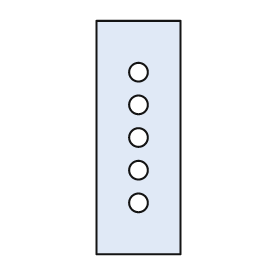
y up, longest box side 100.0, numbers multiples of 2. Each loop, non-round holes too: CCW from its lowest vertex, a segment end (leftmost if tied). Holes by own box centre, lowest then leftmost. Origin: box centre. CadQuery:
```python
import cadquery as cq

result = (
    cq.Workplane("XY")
    .moveTo(-18.0, -50.0)
    .lineTo(18.0, -50.0)
    .lineTo(18.0, 50.0)
    .lineTo(-18.0, 50.0)
    .close()
    .moveTo(0.0, -28.0)
    .circle(4.0)
    .moveTo(0.0, -14.0)
    .circle(4.0)
    .moveTo(0.0, 0.0)
    .circle(4.0)
    .moveTo(0.0, 14.0)
    .circle(4.0)
    .moveTo(0.0, 28.0)
    .circle(4.0)
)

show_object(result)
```